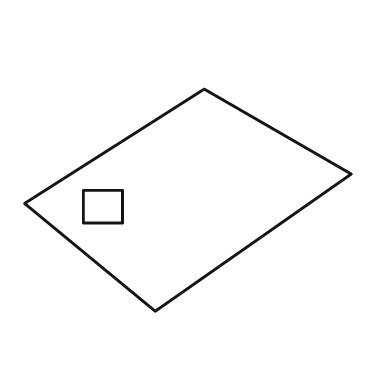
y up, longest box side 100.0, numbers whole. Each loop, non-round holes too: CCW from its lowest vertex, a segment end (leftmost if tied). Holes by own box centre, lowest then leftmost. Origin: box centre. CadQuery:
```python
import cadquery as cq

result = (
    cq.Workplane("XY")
    .moveTo(-10.0, -34.0)
    .lineTo(50.0, 8.0)
    .lineTo(5.0, 34.0)
    .lineTo(-50.0, -1.0)
    .close()
    .moveTo(-32.0, -7.0)
    .lineTo(-20.0, -7.0)
    .lineTo(-20.0, 3.0)
    .lineTo(-32.0, 3.0)
    .close()
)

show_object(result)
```